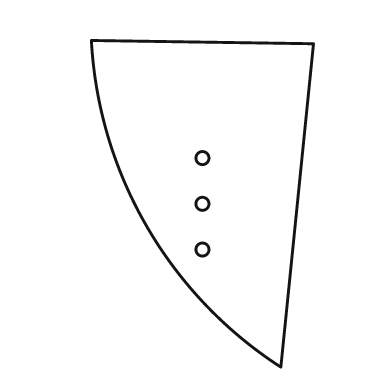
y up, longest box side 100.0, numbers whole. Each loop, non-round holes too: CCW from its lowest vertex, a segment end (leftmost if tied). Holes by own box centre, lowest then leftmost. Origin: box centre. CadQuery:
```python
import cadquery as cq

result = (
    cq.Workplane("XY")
    .moveTo(24.0, -50.0)
    .lineTo(34.0, 49.0)
    .lineTo(-34.0, 50.0)
    .threePointArc((-17.0, -7.0), (24.0, -50.0))
    .close()
    .moveTo(0.0, -14.0)
    .circle(2.0)
    .moveTo(0.0, 0.0)
    .circle(2.0)
    .moveTo(0.0, 14.0)
    .circle(2.0)
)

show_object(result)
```